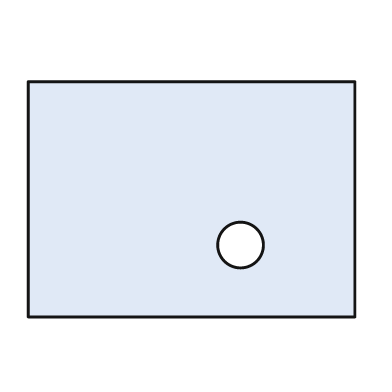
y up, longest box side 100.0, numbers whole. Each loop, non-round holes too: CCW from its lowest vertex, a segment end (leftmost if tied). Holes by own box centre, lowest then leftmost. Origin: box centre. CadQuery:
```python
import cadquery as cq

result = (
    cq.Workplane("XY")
    .moveTo(-50.0, -36.0)
    .lineTo(50.0, -36.0)
    .lineTo(50.0, 36.0)
    .lineTo(-50.0, 36.0)
    .close()
    .moveTo(15.0, -14.0)
    .circle(7.0)
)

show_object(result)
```